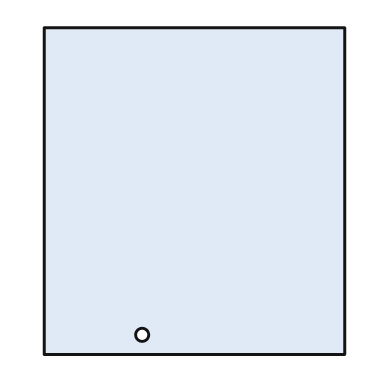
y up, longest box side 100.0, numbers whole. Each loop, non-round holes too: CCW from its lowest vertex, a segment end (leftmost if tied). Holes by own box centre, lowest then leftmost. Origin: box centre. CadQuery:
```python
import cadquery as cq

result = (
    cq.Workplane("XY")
    .moveTo(-46.0, -50.0)
    .lineTo(46.0, -50.0)
    .lineTo(46.0, 50.0)
    .lineTo(-46.0, 50.0)
    .close()
    .moveTo(-16.0, -44.0)
    .circle(2.0)
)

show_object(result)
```